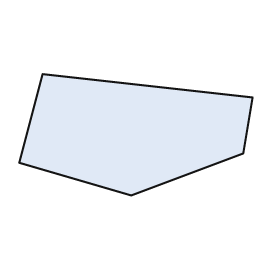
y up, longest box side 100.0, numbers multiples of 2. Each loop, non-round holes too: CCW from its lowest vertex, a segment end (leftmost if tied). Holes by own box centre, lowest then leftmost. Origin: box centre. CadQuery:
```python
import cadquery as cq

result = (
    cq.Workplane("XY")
    .moveTo(-2.0, -26.0)
    .lineTo(46.0, -8.0)
    .lineTo(50.0, 16.0)
    .lineTo(-40.0, 26.0)
    .lineTo(-50.0, -12.0)
    .close()
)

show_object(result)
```